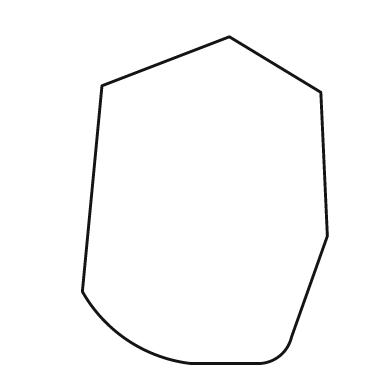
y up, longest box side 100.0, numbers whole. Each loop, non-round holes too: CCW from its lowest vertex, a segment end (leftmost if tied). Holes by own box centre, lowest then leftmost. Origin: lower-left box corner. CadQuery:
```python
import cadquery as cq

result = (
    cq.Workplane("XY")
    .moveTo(33.0, 0.0)
    .lineTo(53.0, 0.0)
    .threePointArc((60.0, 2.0), (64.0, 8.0))
    .lineTo(75.0, 39.0)
    .lineTo(73.0, 83.0)
    .lineTo(45.0, 100.0)
    .lineTo(6.0, 85.0)
    .lineTo(0.0, 22.0)
    .threePointArc((14.0, 7.0), (33.0, 0.0))
    .close()
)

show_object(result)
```